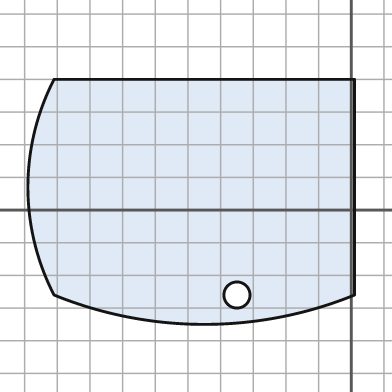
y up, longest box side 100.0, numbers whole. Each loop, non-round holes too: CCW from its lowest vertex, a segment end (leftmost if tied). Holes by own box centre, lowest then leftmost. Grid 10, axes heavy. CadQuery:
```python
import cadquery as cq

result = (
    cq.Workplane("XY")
    .moveTo(-91.0, -26.0)
    .threePointArc((-45.0, -35.0), (1.0, -26.0))
    .lineTo(1.0, 40.0)
    .lineTo(-91.0, 40.0)
    .threePointArc((-99.0, 7.0), (-91.0, -26.0))
    .close()
    .moveTo(-35.0, -26.0)
    .circle(4.0)
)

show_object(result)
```